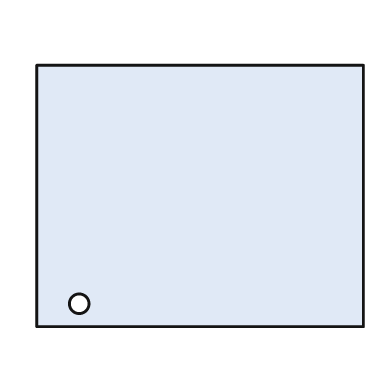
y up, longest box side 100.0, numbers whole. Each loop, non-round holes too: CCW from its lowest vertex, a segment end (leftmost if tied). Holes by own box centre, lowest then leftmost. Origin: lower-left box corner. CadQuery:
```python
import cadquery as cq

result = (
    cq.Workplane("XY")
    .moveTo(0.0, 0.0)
    .lineTo(100.0, 0.0)
    .lineTo(100.0, 80.0)
    .lineTo(0.0, 80.0)
    .close()
    .moveTo(13.0, 7.0)
    .circle(3.0)
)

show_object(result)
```